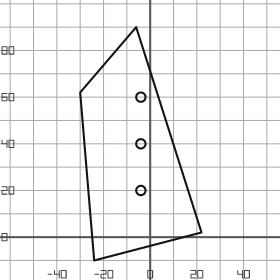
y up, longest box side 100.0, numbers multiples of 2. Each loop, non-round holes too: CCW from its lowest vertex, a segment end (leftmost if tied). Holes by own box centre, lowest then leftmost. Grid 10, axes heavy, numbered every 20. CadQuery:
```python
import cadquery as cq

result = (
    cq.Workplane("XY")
    .moveTo(-24.0, -10.0)
    .lineTo(22.0, 2.0)
    .lineTo(-6.0, 90.0)
    .lineTo(-30.0, 62.0)
    .close()
    .moveTo(-4.0, 20.0)
    .circle(2.0)
    .moveTo(-4.0, 40.0)
    .circle(2.0)
    .moveTo(-4.0, 60.0)
    .circle(2.0)
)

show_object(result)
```